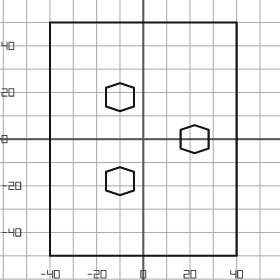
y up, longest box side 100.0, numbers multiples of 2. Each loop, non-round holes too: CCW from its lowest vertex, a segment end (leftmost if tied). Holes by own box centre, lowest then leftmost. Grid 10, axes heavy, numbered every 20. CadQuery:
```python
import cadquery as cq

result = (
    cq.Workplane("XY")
    .moveTo(-40.0, -50.0)
    .lineTo(40.0, -50.0)
    .lineTo(40.0, 50.0)
    .lineTo(-40.0, 50.0)
    .close()
    .moveTo(-10.0, -24.0)
    .lineTo(-4.0, -22.0)
    .lineTo(-4.0, -14.0)
    .lineTo(-10.0, -12.0)
    .lineTo(-16.0, -14.0)
    .lineTo(-16.0, -22.0)
    .close()
    .moveTo(22.0, -6.0)
    .lineTo(28.0, -4.0)
    .lineTo(28.0, 4.0)
    .lineTo(22.0, 6.0)
    .lineTo(16.0, 4.0)
    .lineTo(16.0, -4.0)
    .close()
    .moveTo(-10.0, 12.0)
    .lineTo(-4.0, 14.0)
    .lineTo(-4.0, 22.0)
    .lineTo(-10.0, 24.0)
    .lineTo(-16.0, 22.0)
    .lineTo(-16.0, 14.0)
    .close()
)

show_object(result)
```